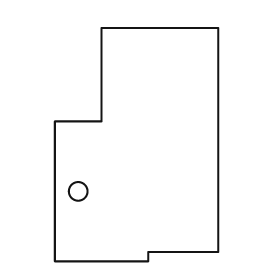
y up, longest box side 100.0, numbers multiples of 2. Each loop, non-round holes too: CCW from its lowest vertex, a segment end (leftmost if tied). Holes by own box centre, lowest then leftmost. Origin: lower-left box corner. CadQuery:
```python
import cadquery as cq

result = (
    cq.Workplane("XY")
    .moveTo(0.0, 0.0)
    .lineTo(40.0, 0.0)
    .lineTo(40.0, 4.0)
    .lineTo(70.0, 4.0)
    .lineTo(70.0, 100.0)
    .lineTo(20.0, 100.0)
    .lineTo(20.0, 60.0)
    .lineTo(0.0, 60.0)
    .close()
    .moveTo(10.0, 30.0)
    .circle(4.0)
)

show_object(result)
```